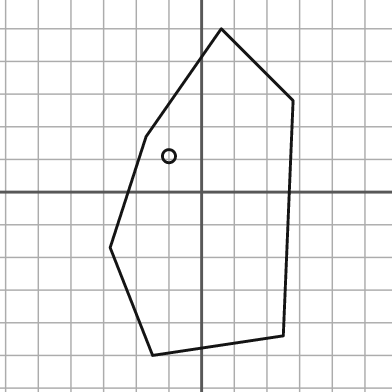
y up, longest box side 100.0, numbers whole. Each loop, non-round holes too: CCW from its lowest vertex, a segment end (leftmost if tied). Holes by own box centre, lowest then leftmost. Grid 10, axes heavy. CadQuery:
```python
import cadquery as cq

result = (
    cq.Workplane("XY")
    .moveTo(-15.0, -50.0)
    .lineTo(25.0, -44.0)
    .lineTo(28.0, 28.0)
    .lineTo(6.0, 50.0)
    .lineTo(-17.0, 17.0)
    .lineTo(-28.0, -17.0)
    .close()
    .moveTo(-10.0, 11.0)
    .circle(2.0)
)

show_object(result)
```